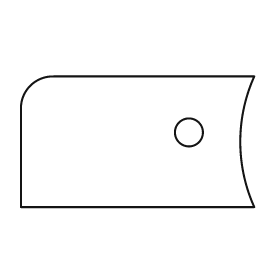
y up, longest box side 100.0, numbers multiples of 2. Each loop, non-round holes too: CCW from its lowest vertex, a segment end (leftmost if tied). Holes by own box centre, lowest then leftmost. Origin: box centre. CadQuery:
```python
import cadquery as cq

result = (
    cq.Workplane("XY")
    .moveTo(-50.0, -28.0)
    .lineTo(50.0, -28.0)
    .threePointArc((44.0, 0.0), (50.0, 28.0))
    .lineTo(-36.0, 28.0)
    .threePointArc((-46.0, 24.0), (-50.0, 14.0))
    .close()
    .moveTo(22.0, 4.0)
    .circle(6.0)
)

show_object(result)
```